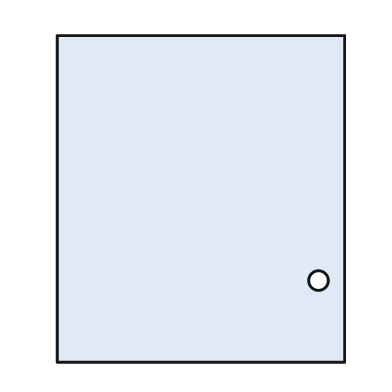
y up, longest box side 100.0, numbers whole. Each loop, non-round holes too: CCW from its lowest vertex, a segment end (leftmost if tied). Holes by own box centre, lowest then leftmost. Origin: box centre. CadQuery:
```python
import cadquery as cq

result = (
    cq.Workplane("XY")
    .moveTo(-44.0, -50.0)
    .lineTo(44.0, -50.0)
    .lineTo(44.0, 50.0)
    .lineTo(-44.0, 50.0)
    .close()
    .moveTo(36.0, -25.0)
    .circle(3.0)
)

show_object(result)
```